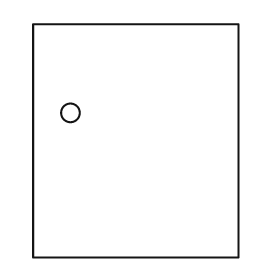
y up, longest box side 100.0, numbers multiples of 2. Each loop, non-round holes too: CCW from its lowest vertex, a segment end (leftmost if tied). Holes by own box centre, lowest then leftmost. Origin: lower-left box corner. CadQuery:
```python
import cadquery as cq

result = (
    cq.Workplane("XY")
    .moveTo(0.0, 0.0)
    .lineTo(88.0, 0.0)
    .lineTo(88.0, 100.0)
    .lineTo(0.0, 100.0)
    .close()
    .moveTo(16.0, 62.0)
    .circle(4.0)
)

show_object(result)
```